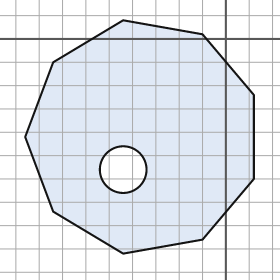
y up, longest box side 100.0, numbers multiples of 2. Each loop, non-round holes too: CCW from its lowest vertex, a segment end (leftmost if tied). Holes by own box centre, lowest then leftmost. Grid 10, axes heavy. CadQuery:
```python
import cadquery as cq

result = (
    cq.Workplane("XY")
    .moveTo(-44.0, -92.0)
    .lineTo(-10.0, -86.0)
    .lineTo(12.0, -60.0)
    .lineTo(12.0, -24.0)
    .lineTo(-10.0, 2.0)
    .lineTo(-44.0, 8.0)
    .lineTo(-74.0, -10.0)
    .lineTo(-86.0, -42.0)
    .lineTo(-74.0, -74.0)
    .close()
    .moveTo(-44.0, -56.0)
    .circle(10.0)
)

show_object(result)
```